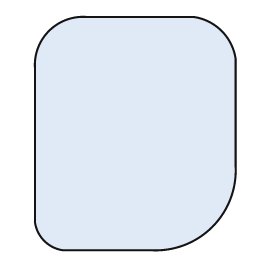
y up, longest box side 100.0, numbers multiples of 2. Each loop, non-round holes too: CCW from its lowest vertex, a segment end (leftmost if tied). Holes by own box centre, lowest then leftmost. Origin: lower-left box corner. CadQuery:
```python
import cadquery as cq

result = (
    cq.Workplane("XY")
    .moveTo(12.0, 0.0)
    .lineTo(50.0, 0.0)
    .threePointArc((76.0, 10.0), (86.0, 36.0))
    .lineTo(86.0, 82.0)
    .threePointArc((80.0, 94.0), (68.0, 100.0))
    .lineTo(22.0, 100.0)
    .threePointArc((6.0, 94.0), (0.0, 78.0))
    .lineTo(0.0, 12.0)
    .threePointArc((4.0, 4.0), (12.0, 0.0))
    .close()
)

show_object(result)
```